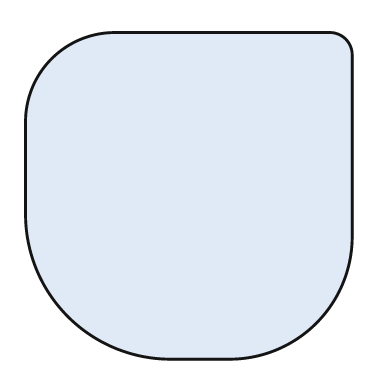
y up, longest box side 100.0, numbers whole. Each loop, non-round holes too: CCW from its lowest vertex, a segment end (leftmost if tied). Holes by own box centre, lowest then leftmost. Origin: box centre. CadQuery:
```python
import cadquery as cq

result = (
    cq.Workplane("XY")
    .moveTo(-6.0, -50.0)
    .lineTo(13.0, -50.0)
    .threePointArc((39.0, -39.0), (50.0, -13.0))
    .lineTo(50.0, 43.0)
    .threePointArc((48.0, 48.0), (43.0, 50.0))
    .lineTo(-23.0, 50.0)
    .threePointArc((-42.0, 42.0), (-50.0, 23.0))
    .lineTo(-50.0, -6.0)
    .threePointArc((-37.0, -37.0), (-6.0, -50.0))
    .close()
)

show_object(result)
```